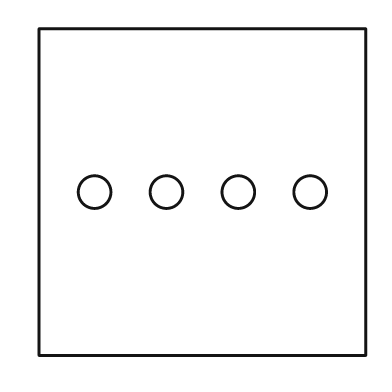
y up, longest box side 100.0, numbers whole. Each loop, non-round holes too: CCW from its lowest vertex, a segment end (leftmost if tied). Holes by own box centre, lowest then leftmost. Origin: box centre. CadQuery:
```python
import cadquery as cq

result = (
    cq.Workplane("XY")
    .moveTo(-50.0, -50.0)
    .lineTo(50.0, -50.0)
    .lineTo(50.0, 50.0)
    .lineTo(-50.0, 50.0)
    .close()
    .moveTo(-33.0, 0.0)
    .circle(5.0)
    .moveTo(-11.0, 0.0)
    .circle(5.0)
    .moveTo(11.0, 0.0)
    .circle(5.0)
    .moveTo(33.0, 0.0)
    .circle(5.0)
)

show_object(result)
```